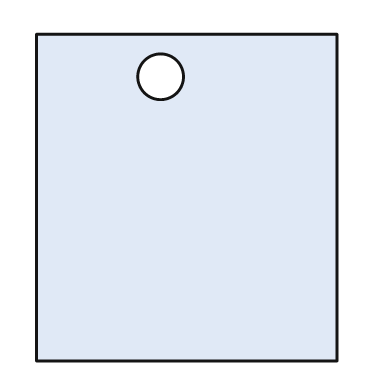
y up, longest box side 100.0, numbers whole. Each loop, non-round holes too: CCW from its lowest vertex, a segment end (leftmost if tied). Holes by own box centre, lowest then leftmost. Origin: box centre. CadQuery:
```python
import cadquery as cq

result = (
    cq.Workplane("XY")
    .moveTo(-46.0, -50.0)
    .lineTo(46.0, -50.0)
    .lineTo(46.0, 50.0)
    .lineTo(-46.0, 50.0)
    .close()
    .moveTo(-8.0, 37.0)
    .circle(7.0)
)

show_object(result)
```